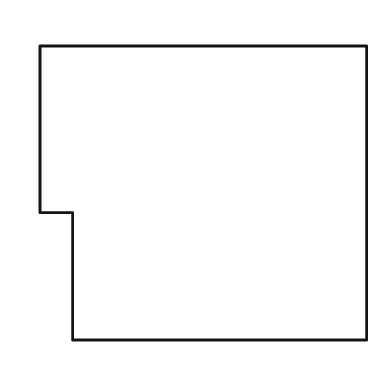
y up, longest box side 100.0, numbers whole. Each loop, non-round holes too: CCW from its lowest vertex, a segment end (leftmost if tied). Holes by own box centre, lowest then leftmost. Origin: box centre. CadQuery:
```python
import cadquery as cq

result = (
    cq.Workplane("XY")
    .moveTo(-40.0, -45.0)
    .lineTo(50.0, -45.0)
    .lineTo(50.0, 45.0)
    .lineTo(-50.0, 45.0)
    .lineTo(-50.0, -6.0)
    .lineTo(-40.0, -6.0)
    .close()
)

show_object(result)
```